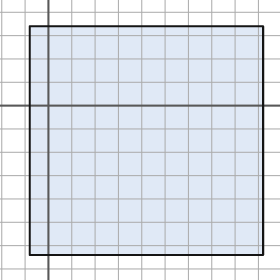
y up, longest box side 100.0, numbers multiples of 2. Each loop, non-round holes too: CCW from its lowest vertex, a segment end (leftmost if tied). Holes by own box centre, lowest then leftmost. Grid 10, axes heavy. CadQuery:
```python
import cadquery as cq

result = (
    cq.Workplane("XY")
    .moveTo(-8.0, -64.0)
    .lineTo(92.0, -64.0)
    .lineTo(92.0, 34.0)
    .lineTo(-8.0, 34.0)
    .close()
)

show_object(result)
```